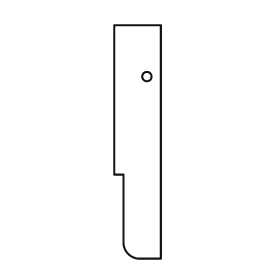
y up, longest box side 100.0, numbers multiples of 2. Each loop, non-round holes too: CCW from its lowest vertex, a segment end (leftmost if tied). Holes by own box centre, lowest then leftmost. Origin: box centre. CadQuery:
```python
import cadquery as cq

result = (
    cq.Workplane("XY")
    .moveTo(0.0, -50.0)
    .lineTo(10.0, -50.0)
    .lineTo(10.0, 50.0)
    .lineTo(-10.0, 50.0)
    .lineTo(-10.0, -14.0)
    .lineTo(-6.0, -14.0)
    .lineTo(-6.0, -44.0)
    .threePointArc((-4.0, -48.0), (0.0, -50.0))
    .close()
    .moveTo(4.0, 28.0)
    .circle(2.0)
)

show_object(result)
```